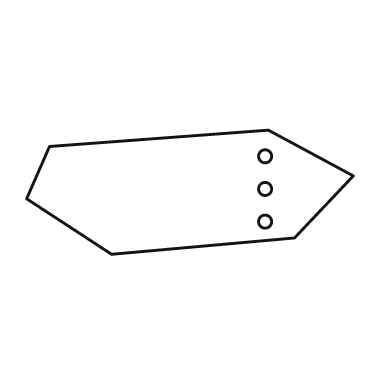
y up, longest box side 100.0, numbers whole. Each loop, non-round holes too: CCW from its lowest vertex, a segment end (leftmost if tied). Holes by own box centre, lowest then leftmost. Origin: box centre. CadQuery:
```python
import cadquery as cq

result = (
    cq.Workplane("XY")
    .moveTo(-24.0, -19.0)
    .lineTo(32.0, -14.0)
    .lineTo(50.0, 5.0)
    .lineTo(24.0, 19.0)
    .lineTo(-43.0, 14.0)
    .lineTo(-50.0, -2.0)
    .close()
    .moveTo(23.0, -9.0)
    .circle(2.0)
    .moveTo(23.0, 1.0)
    .circle(2.0)
    .moveTo(23.0, 11.0)
    .circle(2.0)
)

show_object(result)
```